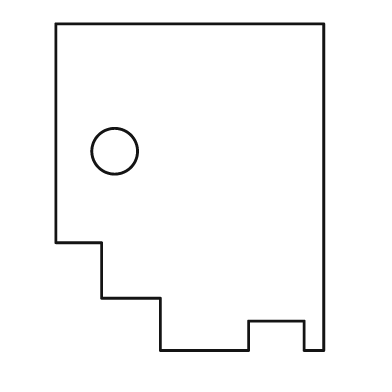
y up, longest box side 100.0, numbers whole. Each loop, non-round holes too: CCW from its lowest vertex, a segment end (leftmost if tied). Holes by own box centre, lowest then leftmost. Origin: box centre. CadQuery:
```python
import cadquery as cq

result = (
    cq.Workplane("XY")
    .moveTo(-9.0, -50.0)
    .lineTo(18.0, -50.0)
    .lineTo(18.0, -41.0)
    .lineTo(35.0, -41.0)
    .lineTo(35.0, -50.0)
    .lineTo(41.0, -50.0)
    .lineTo(41.0, 50.0)
    .lineTo(-41.0, 50.0)
    .lineTo(-41.0, -17.0)
    .lineTo(-27.0, -17.0)
    .lineTo(-27.0, -34.0)
    .lineTo(-9.0, -34.0)
    .close()
    .moveTo(-23.0, 11.0)
    .circle(7.0)
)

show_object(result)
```